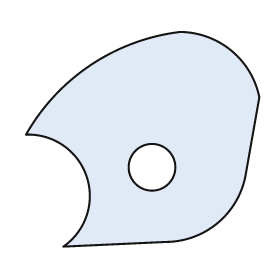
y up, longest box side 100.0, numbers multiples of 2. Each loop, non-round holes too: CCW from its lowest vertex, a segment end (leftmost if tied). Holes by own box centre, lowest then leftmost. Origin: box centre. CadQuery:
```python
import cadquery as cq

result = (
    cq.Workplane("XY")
    .moveTo(-34.0, -46.0)
    .lineTo(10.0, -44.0)
    .threePointArc((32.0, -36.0), (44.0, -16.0))
    .lineTo(50.0, 18.0)
    .threePointArc((38.0, 38.0), (16.0, 46.0))
    .threePointArc((-22.0, 32.0), (-50.0, 2.0))
    .threePointArc((-24.0, -16.0), (-34.0, -46.0))
    .close()
    .moveTo(4.0, -12.0)
    .circle(10.0)
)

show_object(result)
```